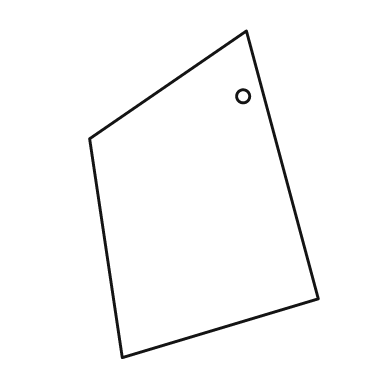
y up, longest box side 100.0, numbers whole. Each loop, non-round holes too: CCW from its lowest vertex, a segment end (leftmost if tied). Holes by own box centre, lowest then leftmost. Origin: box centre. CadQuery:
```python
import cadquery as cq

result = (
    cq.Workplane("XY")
    .moveTo(-25.0, -50.0)
    .lineTo(35.0, -32.0)
    .lineTo(13.0, 50.0)
    .lineTo(-35.0, 17.0)
    .close()
    .moveTo(12.0, 30.0)
    .circle(2.0)
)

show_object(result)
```